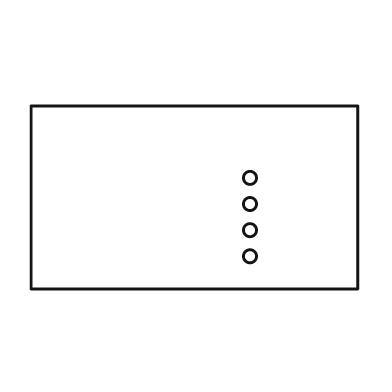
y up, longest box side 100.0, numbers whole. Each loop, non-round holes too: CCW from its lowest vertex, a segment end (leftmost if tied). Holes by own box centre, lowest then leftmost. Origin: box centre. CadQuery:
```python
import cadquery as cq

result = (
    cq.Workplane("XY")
    .moveTo(-50.0, -28.0)
    .lineTo(50.0, -28.0)
    .lineTo(50.0, 28.0)
    .lineTo(-50.0, 28.0)
    .close()
    .moveTo(17.0, -18.0)
    .circle(2.0)
    .moveTo(17.0, -10.0)
    .circle(2.0)
    .moveTo(17.0, -2.0)
    .circle(2.0)
    .moveTo(17.0, 6.0)
    .circle(2.0)
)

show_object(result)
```